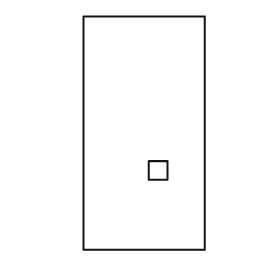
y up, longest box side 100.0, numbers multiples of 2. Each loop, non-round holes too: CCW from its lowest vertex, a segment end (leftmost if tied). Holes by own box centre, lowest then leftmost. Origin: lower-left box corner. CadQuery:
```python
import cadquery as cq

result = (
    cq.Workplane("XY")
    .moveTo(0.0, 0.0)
    .lineTo(52.0, 0.0)
    .lineTo(52.0, 100.0)
    .lineTo(0.0, 100.0)
    .close()
    .moveTo(28.0, 30.0)
    .lineTo(36.0, 30.0)
    .lineTo(36.0, 38.0)
    .lineTo(28.0, 38.0)
    .close()
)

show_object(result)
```